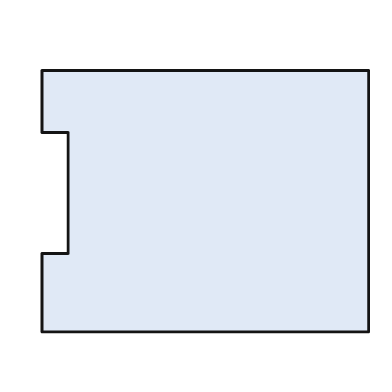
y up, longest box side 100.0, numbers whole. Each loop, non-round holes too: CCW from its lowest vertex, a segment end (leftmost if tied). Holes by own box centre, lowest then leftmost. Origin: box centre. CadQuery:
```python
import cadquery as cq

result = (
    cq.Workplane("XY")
    .moveTo(-50.0, -40.0)
    .lineTo(50.0, -40.0)
    .lineTo(50.0, 40.0)
    .lineTo(-50.0, 40.0)
    .lineTo(-50.0, 21.0)
    .lineTo(-42.0, 21.0)
    .lineTo(-42.0, -16.0)
    .lineTo(-50.0, -16.0)
    .close()
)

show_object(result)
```